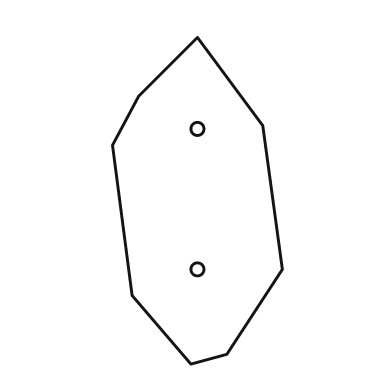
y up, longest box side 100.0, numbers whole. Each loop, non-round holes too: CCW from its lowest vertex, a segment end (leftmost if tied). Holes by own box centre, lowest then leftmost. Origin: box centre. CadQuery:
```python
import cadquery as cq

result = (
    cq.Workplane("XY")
    .moveTo(-2.0, -50.0)
    .lineTo(9.0, -47.0)
    .lineTo(26.0, -21.0)
    .lineTo(20.0, 23.0)
    .lineTo(0.0, 50.0)
    .lineTo(-18.0, 32.0)
    .lineTo(-26.0, 17.0)
    .lineTo(-20.0, -29.0)
    .close()
    .moveTo(0.0, -21.0)
    .circle(2.0)
    .moveTo(0.0, 22.0)
    .circle(2.0)
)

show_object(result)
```